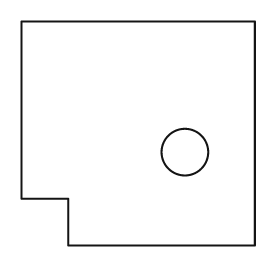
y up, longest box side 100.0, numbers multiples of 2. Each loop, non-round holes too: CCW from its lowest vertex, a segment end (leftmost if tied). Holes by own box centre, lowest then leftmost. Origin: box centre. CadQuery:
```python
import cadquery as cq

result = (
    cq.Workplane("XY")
    .moveTo(-30.0, -48.0)
    .lineTo(50.0, -48.0)
    .lineTo(50.0, 48.0)
    .lineTo(-50.0, 48.0)
    .lineTo(-50.0, -28.0)
    .lineTo(-30.0, -28.0)
    .close()
    .moveTo(20.0, -8.0)
    .circle(10.0)
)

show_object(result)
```